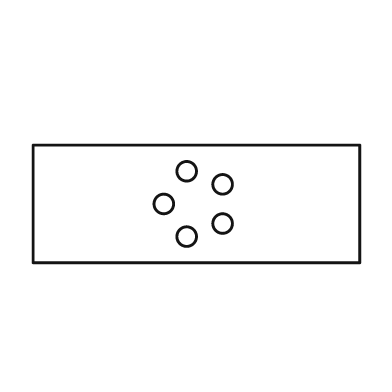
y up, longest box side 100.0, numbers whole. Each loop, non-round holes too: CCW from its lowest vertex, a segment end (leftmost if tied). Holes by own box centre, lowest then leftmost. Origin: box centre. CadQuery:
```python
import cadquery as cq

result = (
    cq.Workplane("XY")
    .moveTo(-50.0, -18.0)
    .lineTo(50.0, -18.0)
    .lineTo(50.0, 18.0)
    .lineTo(-50.0, 18.0)
    .close()
    .moveTo(-3.0, -10.0)
    .circle(3.0)
    .moveTo(8.0, -6.0)
    .circle(3.0)
    .moveTo(-10.0, 0.0)
    .circle(3.0)
    .moveTo(8.0, 6.0)
    .circle(3.0)
    .moveTo(-3.0, 10.0)
    .circle(3.0)
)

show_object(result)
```